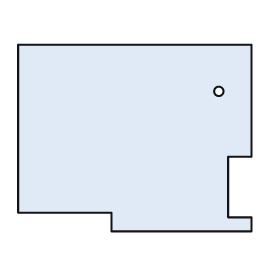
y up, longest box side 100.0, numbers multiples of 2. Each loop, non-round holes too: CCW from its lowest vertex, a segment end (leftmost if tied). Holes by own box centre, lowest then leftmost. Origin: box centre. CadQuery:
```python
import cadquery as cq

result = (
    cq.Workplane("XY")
    .moveTo(-10.0, -40.0)
    .lineTo(50.0, -40.0)
    .lineTo(50.0, -34.0)
    .lineTo(40.0, -34.0)
    .lineTo(40.0, -8.0)
    .lineTo(50.0, -8.0)
    .lineTo(50.0, 40.0)
    .lineTo(-50.0, 40.0)
    .lineTo(-50.0, -32.0)
    .lineTo(-10.0, -32.0)
    .close()
    .moveTo(36.0, 20.0)
    .circle(2.0)
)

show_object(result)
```